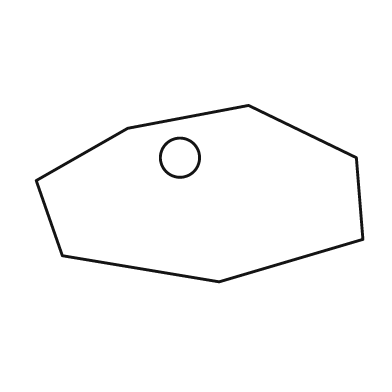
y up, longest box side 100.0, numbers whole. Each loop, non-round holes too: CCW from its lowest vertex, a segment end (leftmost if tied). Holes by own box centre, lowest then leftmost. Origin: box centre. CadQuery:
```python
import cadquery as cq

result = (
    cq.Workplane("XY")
    .moveTo(6.0, -27.0)
    .lineTo(50.0, -14.0)
    .lineTo(48.0, 11.0)
    .lineTo(15.0, 27.0)
    .lineTo(-22.0, 20.0)
    .lineTo(-50.0, 4.0)
    .lineTo(-42.0, -19.0)
    .close()
    .moveTo(-6.0, 11.0)
    .circle(6.0)
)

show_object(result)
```